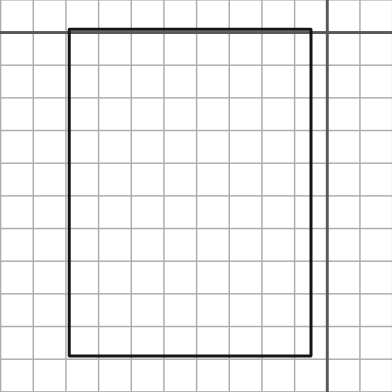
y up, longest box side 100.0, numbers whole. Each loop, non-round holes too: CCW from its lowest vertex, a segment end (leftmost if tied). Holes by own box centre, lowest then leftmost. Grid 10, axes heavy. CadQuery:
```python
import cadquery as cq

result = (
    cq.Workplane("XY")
    .moveTo(-79.0, -99.0)
    .lineTo(-5.0, -99.0)
    .lineTo(-5.0, 1.0)
    .lineTo(-79.0, 1.0)
    .close()
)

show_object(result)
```